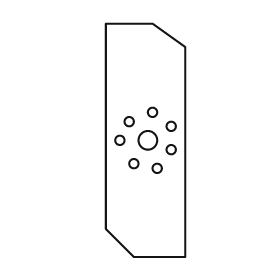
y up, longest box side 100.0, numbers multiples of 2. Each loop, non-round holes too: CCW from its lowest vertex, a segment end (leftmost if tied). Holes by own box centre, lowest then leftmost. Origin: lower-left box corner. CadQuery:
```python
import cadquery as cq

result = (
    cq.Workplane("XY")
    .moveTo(12.0, 0.0)
    .lineTo(34.0, 0.0)
    .lineTo(34.0, 90.0)
    .lineTo(20.0, 100.0)
    .lineTo(0.0, 100.0)
    .lineTo(0.0, 12.0)
    .close()
    .moveTo(22.0, 38.0)
    .circle(2.0)
    .moveTo(12.0, 40.0)
    .circle(2.0)
    .moveTo(28.0, 46.0)
    .circle(2.0)
    .moveTo(6.0, 50.0)
    .circle(2.0)
    .moveTo(18.0, 50.0)
    .circle(4.0)
    .moveTo(28.0, 56.0)
    .circle(2.0)
    .moveTo(10.0, 58.0)
    .circle(2.0)
    .moveTo(20.0, 62.0)
    .circle(2.0)
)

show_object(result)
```